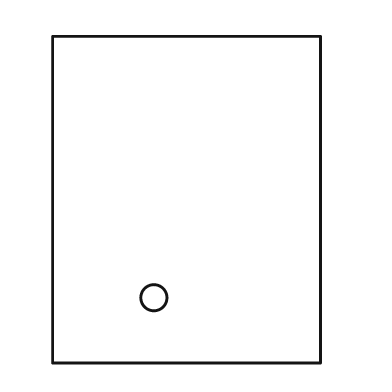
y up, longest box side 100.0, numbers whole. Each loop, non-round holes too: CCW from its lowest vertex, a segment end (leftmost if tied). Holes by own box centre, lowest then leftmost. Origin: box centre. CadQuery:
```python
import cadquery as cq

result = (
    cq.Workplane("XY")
    .moveTo(-41.0, -50.0)
    .lineTo(41.0, -50.0)
    .lineTo(41.0, 50.0)
    .lineTo(-41.0, 50.0)
    .close()
    .moveTo(-10.0, -30.0)
    .circle(4.0)
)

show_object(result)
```